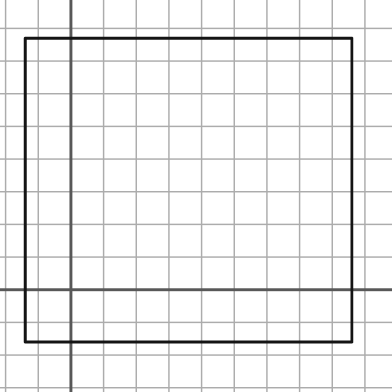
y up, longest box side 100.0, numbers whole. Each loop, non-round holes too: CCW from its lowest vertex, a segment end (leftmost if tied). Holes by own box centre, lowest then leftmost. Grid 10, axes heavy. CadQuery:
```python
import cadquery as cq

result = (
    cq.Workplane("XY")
    .moveTo(-14.0, -16.0)
    .lineTo(86.0, -16.0)
    .lineTo(86.0, 77.0)
    .lineTo(-14.0, 77.0)
    .close()
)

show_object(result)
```